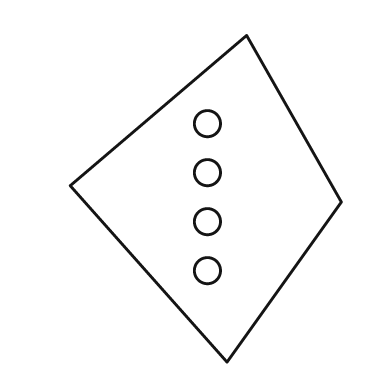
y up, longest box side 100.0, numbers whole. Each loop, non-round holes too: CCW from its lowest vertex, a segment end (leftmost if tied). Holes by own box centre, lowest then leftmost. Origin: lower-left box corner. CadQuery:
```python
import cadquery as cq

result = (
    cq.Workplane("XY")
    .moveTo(48.0, 0.0)
    .lineTo(83.0, 49.0)
    .lineTo(54.0, 100.0)
    .lineTo(0.0, 54.0)
    .close()
    .moveTo(42.0, 28.0)
    .circle(4.0)
    .moveTo(42.0, 43.0)
    .circle(4.0)
    .moveTo(42.0, 58.0)
    .circle(4.0)
    .moveTo(42.0, 73.0)
    .circle(4.0)
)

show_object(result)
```